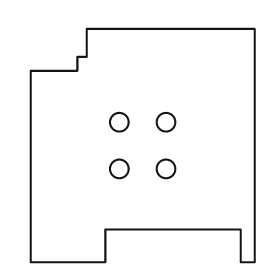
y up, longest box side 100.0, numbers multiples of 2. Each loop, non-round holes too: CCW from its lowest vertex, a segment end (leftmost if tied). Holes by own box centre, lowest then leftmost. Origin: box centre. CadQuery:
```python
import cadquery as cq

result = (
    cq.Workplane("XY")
    .moveTo(-48.0, -50.0)
    .lineTo(-16.0, -50.0)
    .lineTo(-16.0, -36.0)
    .lineTo(42.0, -36.0)
    .lineTo(42.0, -50.0)
    .lineTo(48.0, -50.0)
    .lineTo(48.0, 50.0)
    .lineTo(-24.0, 50.0)
    .lineTo(-24.0, 38.0)
    .lineTo(-28.0, 38.0)
    .lineTo(-28.0, 32.0)
    .lineTo(-48.0, 32.0)
    .close()
    .moveTo(-10.0, -10.0)
    .circle(4.0)
    .moveTo(10.0, -10.0)
    .circle(4.0)
    .moveTo(-10.0, 10.0)
    .circle(4.0)
    .moveTo(10.0, 10.0)
    .circle(4.0)
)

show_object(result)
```